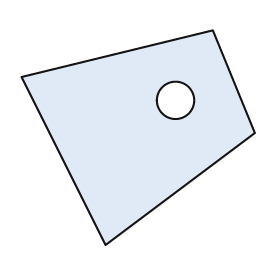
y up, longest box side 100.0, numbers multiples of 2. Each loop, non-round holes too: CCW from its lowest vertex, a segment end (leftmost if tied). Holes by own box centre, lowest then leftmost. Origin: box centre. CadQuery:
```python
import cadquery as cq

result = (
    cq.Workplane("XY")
    .moveTo(-14.0, -46.0)
    .lineTo(50.0, 2.0)
    .lineTo(32.0, 46.0)
    .lineTo(-50.0, 26.0)
    .close()
    .moveTo(16.0, 16.0)
    .circle(8.0)
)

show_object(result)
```